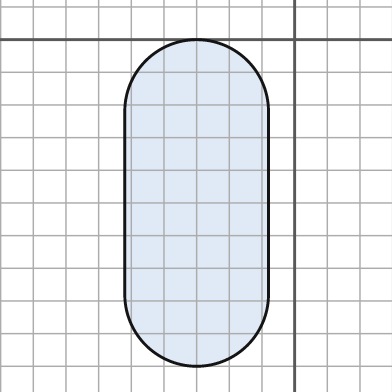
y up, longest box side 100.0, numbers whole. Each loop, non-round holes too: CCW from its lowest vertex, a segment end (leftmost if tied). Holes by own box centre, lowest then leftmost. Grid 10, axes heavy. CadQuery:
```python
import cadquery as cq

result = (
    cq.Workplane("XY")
    .moveTo(-52.0, -78.0)
    .threePointArc((-30.0, -100.0), (-8.0, -78.0))
    .lineTo(-8.0, -22.0)
    .threePointArc((-30.0, 0.0), (-52.0, -22.0))
    .close()
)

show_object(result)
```